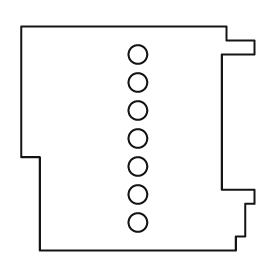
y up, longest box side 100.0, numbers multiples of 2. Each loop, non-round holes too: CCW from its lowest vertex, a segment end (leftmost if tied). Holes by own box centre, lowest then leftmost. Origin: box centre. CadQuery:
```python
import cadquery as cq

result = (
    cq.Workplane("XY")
    .moveTo(-42.0, -48.0)
    .lineTo(42.0, -48.0)
    .lineTo(42.0, -42.0)
    .lineTo(46.0, -42.0)
    .lineTo(46.0, -28.0)
    .lineTo(50.0, -28.0)
    .lineTo(50.0, -22.0)
    .lineTo(36.0, -22.0)
    .lineTo(36.0, 36.0)
    .lineTo(50.0, 36.0)
    .lineTo(50.0, 42.0)
    .lineTo(38.0, 42.0)
    .lineTo(38.0, 48.0)
    .lineTo(-50.0, 48.0)
    .lineTo(-50.0, -8.0)
    .lineTo(-42.0, -8.0)
    .close()
    .moveTo(0.0, -36.0)
    .circle(4.0)
    .moveTo(0.0, -24.0)
    .circle(4.0)
    .moveTo(0.0, -12.0)
    .circle(4.0)
    .moveTo(0.0, 0.0)
    .circle(4.0)
    .moveTo(0.0, 12.0)
    .circle(4.0)
    .moveTo(0.0, 24.0)
    .circle(4.0)
    .moveTo(0.0, 36.0)
    .circle(4.0)
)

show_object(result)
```